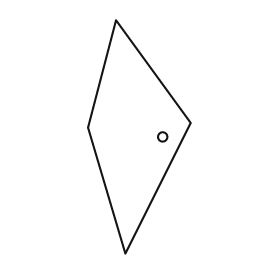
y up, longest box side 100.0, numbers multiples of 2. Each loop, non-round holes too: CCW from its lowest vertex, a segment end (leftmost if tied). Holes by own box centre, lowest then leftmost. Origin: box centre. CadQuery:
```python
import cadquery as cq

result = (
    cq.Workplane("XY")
    .moveTo(-6.0, -50.0)
    .lineTo(22.0, 6.0)
    .lineTo(-10.0, 50.0)
    .lineTo(-22.0, 4.0)
    .close()
    .moveTo(10.0, 0.0)
    .circle(2.0)
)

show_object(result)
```